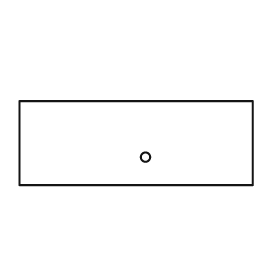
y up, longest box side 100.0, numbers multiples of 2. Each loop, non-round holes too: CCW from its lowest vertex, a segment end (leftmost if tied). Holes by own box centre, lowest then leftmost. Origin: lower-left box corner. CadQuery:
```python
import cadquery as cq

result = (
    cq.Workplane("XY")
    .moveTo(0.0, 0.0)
    .lineTo(100.0, 0.0)
    .lineTo(100.0, 36.0)
    .lineTo(0.0, 36.0)
    .close()
    .moveTo(54.0, 12.0)
    .circle(2.0)
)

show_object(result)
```